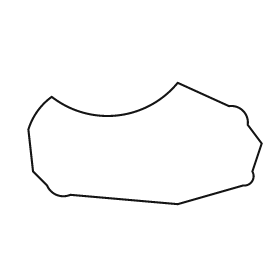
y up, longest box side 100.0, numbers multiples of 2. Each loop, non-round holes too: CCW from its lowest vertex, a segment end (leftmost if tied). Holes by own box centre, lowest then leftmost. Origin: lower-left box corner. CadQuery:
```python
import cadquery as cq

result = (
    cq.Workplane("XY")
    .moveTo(64.0, 0.0)
    .lineTo(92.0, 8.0)
    .threePointArc((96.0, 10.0), (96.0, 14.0))
    .lineTo(100.0, 26.0)
    .lineTo(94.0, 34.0)
    .threePointArc((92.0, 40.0), (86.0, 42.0))
    .lineTo(64.0, 52.0)
    .threePointArc((38.0, 38.0), (10.0, 46.0))
    .threePointArc((4.0, 40.0), (0.0, 32.0))
    .lineTo(2.0, 14.0)
    .lineTo(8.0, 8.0)
    .threePointArc((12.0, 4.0), (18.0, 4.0))
    .close()
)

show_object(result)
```